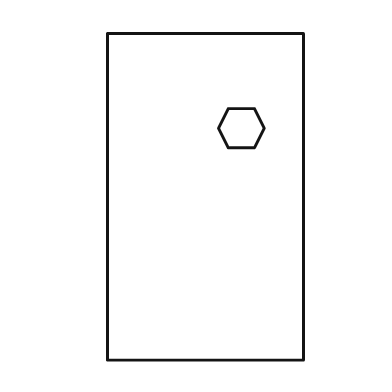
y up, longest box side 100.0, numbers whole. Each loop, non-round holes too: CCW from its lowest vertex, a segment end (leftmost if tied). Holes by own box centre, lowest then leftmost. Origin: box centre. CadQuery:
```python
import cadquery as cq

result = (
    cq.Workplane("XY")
    .moveTo(-30.0, -50.0)
    .lineTo(30.0, -50.0)
    .lineTo(30.0, 50.0)
    .lineTo(-30.0, 50.0)
    .close()
    .moveTo(7.0, 15.0)
    .lineTo(15.0, 15.0)
    .lineTo(18.0, 21.0)
    .lineTo(15.0, 27.0)
    .lineTo(7.0, 27.0)
    .lineTo(4.0, 21.0)
    .close()
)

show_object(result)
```